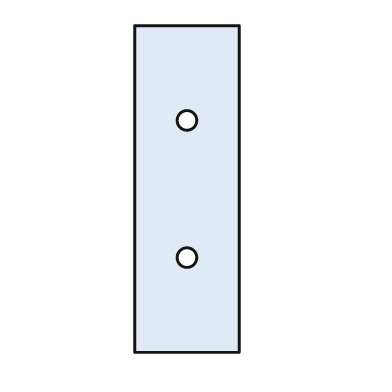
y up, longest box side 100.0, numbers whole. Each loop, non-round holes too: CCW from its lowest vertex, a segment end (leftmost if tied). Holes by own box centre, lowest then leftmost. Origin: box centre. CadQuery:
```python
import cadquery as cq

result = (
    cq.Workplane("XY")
    .moveTo(-16.0, -50.0)
    .lineTo(16.0, -50.0)
    .lineTo(16.0, 50.0)
    .lineTo(-16.0, 50.0)
    .close()
    .moveTo(0.0, -21.0)
    .circle(3.0)
    .moveTo(0.0, 21.0)
    .circle(3.0)
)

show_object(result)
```